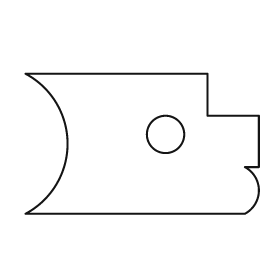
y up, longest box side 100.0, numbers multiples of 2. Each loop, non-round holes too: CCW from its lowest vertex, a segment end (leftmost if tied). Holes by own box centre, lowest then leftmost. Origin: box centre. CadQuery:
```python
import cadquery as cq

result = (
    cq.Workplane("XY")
    .moveTo(-50.0, -30.0)
    .lineTo(44.0, -30.0)
    .threePointArc((50.0, -20.0), (44.0, -10.0))
    .lineTo(50.0, -10.0)
    .lineTo(50.0, 12.0)
    .lineTo(28.0, 12.0)
    .lineTo(28.0, 30.0)
    .lineTo(-50.0, 30.0)
    .threePointArc((-32.0, 0.0), (-50.0, -30.0))
    .close()
    .moveTo(10.0, 4.0)
    .circle(8.0)
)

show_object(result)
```